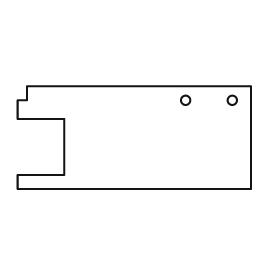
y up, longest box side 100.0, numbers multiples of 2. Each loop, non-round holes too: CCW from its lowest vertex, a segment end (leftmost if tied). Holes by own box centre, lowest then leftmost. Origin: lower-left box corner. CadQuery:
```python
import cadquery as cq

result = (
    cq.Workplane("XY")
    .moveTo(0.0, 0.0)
    .lineTo(100.0, 0.0)
    .lineTo(100.0, 44.0)
    .lineTo(4.0, 44.0)
    .lineTo(4.0, 38.0)
    .lineTo(0.0, 38.0)
    .lineTo(0.0, 30.0)
    .lineTo(20.0, 30.0)
    .lineTo(20.0, 6.0)
    .lineTo(0.0, 6.0)
    .close()
    .moveTo(72.0, 38.0)
    .circle(2.0)
    .moveTo(92.0, 38.0)
    .circle(2.0)
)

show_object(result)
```